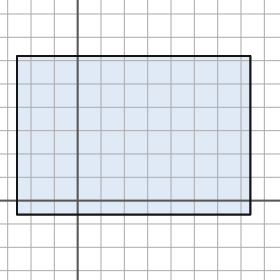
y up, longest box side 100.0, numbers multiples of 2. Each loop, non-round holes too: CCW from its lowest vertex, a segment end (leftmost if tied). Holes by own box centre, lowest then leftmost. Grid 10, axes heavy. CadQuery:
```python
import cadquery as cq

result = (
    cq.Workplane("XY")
    .moveTo(-26.0, -6.0)
    .lineTo(74.0, -6.0)
    .lineTo(74.0, 62.0)
    .lineTo(-26.0, 62.0)
    .close()
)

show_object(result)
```